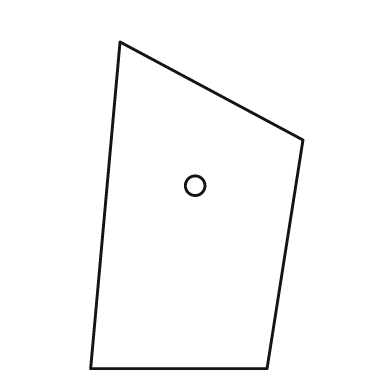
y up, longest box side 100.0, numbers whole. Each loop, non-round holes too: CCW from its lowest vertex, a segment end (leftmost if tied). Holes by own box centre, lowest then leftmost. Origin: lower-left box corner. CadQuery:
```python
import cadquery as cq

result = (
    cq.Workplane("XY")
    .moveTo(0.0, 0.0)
    .lineTo(54.0, 0.0)
    .lineTo(65.0, 70.0)
    .lineTo(9.0, 100.0)
    .close()
    .moveTo(32.0, 56.0)
    .circle(3.0)
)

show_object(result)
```